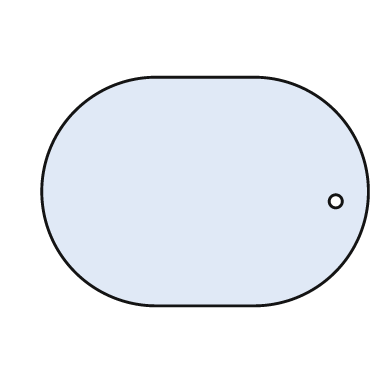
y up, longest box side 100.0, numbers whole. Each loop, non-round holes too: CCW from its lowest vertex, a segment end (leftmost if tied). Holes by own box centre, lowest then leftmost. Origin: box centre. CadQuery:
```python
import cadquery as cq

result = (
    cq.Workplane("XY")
    .moveTo(-15.0, -35.0)
    .lineTo(15.0, -35.0)
    .threePointArc((50.0, 0.0), (15.0, 35.0))
    .lineTo(-15.0, 35.0)
    .threePointArc((-50.0, 0.0), (-15.0, -35.0))
    .close()
    .moveTo(40.0, -3.0)
    .circle(2.0)
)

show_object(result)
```